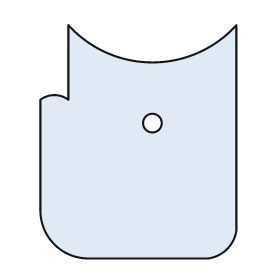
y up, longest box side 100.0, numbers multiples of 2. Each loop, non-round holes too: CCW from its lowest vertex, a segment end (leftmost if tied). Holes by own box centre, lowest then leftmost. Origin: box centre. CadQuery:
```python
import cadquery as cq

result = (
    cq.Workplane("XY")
    .moveTo(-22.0, -50.0)
    .lineTo(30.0, -50.0)
    .threePointArc((38.0, -46.0), (42.0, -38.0))
    .lineTo(42.0, 50.0)
    .threePointArc((6.0, 34.0), (-30.0, 50.0))
    .lineTo(-30.0, 18.0)
    .threePointArc((-36.0, 20.0), (-42.0, 18.0))
    .lineTo(-42.0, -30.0)
    .threePointArc((-36.0, -44.0), (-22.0, -50.0))
    .close()
    .moveTo(6.0, 8.0)
    .circle(4.0)
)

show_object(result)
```